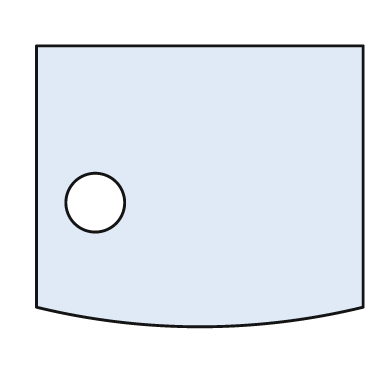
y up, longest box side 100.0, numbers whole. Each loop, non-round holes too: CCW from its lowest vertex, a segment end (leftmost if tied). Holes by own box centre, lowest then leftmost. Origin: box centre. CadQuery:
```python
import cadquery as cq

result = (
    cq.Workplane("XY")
    .moveTo(-50.0, -37.0)
    .threePointArc((0.0, -43.0), (50.0, -37.0))
    .lineTo(50.0, 43.0)
    .lineTo(-50.0, 43.0)
    .close()
    .moveTo(-32.0, -5.0)
    .circle(9.0)
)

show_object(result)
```